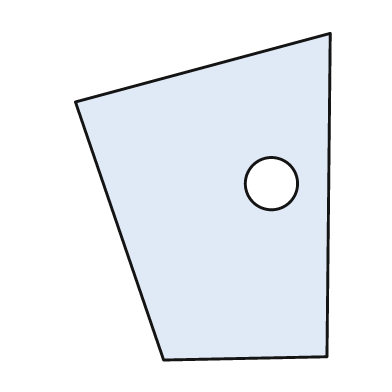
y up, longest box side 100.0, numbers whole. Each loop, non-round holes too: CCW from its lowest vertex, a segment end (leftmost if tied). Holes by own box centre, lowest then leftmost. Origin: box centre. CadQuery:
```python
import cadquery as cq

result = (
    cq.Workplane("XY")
    .moveTo(-12.0, -50.0)
    .lineTo(38.0, -49.0)
    .lineTo(39.0, 50.0)
    .lineTo(-39.0, 29.0)
    .close()
    .moveTo(21.0, 4.0)
    .circle(8.0)
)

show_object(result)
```